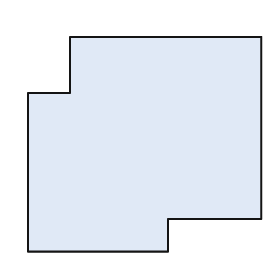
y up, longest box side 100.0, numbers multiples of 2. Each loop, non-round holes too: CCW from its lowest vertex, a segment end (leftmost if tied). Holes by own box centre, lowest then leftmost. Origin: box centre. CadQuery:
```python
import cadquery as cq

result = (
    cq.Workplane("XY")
    .moveTo(-50.0, -46.0)
    .lineTo(10.0, -46.0)
    .lineTo(10.0, -32.0)
    .lineTo(50.0, -32.0)
    .lineTo(50.0, 46.0)
    .lineTo(-32.0, 46.0)
    .lineTo(-32.0, 22.0)
    .lineTo(-50.0, 22.0)
    .close()
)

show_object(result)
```